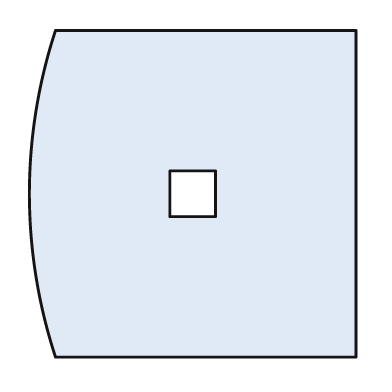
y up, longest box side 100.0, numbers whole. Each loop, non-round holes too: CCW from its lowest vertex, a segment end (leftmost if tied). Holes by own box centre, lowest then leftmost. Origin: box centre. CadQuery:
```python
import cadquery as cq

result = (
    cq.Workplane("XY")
    .moveTo(-42.0, -50.0)
    .lineTo(50.0, -50.0)
    .lineTo(50.0, 50.0)
    .lineTo(-42.0, 50.0)
    .threePointArc((-50.0, 0.0), (-42.0, -50.0))
    .close()
    .moveTo(-7.0, -7.0)
    .lineTo(7.0, -7.0)
    .lineTo(7.0, 7.0)
    .lineTo(-7.0, 7.0)
    .close()
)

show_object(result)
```